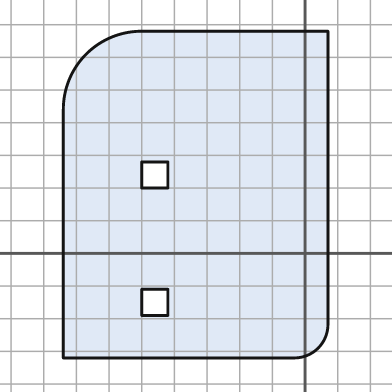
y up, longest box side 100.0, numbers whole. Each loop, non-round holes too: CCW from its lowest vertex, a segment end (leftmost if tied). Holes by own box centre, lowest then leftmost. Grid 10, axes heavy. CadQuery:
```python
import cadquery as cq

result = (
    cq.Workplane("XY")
    .moveTo(-74.0, -32.0)
    .lineTo(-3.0, -32.0)
    .threePointArc((4.0, -29.0), (7.0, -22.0))
    .lineTo(7.0, 68.0)
    .lineTo(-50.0, 68.0)
    .threePointArc((-67.0, 61.0), (-74.0, 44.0))
    .close()
    .moveTo(-50.0, -19.0)
    .lineTo(-42.0, -19.0)
    .lineTo(-42.0, -11.0)
    .lineTo(-50.0, -11.0)
    .close()
    .moveTo(-50.0, 20.0)
    .lineTo(-42.0, 20.0)
    .lineTo(-42.0, 28.0)
    .lineTo(-50.0, 28.0)
    .close()
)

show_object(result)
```